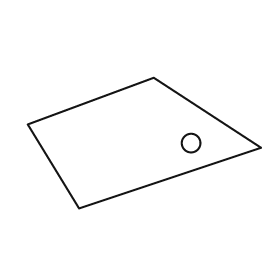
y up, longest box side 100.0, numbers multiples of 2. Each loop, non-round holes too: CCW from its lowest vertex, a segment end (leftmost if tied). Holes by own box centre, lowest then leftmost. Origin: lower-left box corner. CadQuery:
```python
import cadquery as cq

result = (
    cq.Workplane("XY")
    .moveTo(22.0, 0.0)
    .lineTo(100.0, 26.0)
    .lineTo(54.0, 56.0)
    .lineTo(0.0, 36.0)
    .close()
    .moveTo(70.0, 28.0)
    .circle(4.0)
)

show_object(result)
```